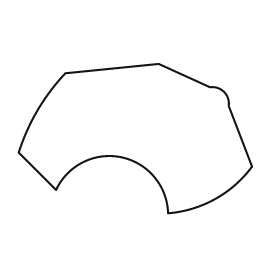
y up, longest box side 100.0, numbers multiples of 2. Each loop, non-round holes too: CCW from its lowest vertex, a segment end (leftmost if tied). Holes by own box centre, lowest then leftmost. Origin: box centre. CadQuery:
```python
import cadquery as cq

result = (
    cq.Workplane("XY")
    .moveTo(14.0, -32.0)
    .threePointArc((34.0, -26.0), (50.0, -12.0))
    .lineTo(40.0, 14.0)
    .threePointArc((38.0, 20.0), (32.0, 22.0))
    .lineTo(10.0, 32.0)
    .lineTo(-30.0, 28.0)
    .threePointArc((-42.0, 12.0), (-50.0, -6.0))
    .lineTo(-34.0, -22.0)
    .threePointArc((-6.0, -8.0), (14.0, -32.0))
    .close()
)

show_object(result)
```